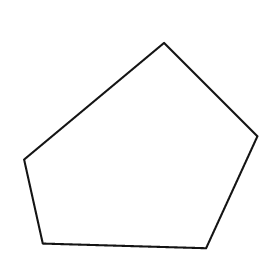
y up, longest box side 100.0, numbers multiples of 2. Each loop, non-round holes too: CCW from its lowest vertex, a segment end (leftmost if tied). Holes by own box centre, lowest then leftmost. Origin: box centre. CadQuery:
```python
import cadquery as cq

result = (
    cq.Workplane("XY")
    .moveTo(28.0, -44.0)
    .lineTo(50.0, 4.0)
    .lineTo(10.0, 44.0)
    .lineTo(-50.0, -6.0)
    .lineTo(-42.0, -42.0)
    .close()
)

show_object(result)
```